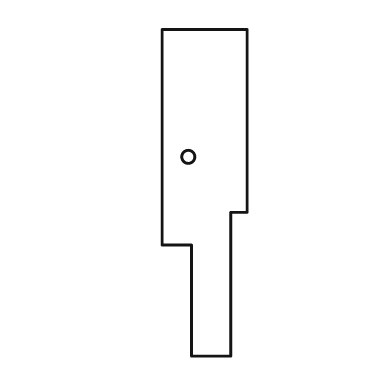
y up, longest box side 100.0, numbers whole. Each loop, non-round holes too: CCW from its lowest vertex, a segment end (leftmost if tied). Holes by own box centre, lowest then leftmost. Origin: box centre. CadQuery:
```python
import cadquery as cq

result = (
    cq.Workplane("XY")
    .moveTo(-4.0, -50.0)
    .lineTo(8.0, -50.0)
    .lineTo(8.0, -6.0)
    .lineTo(13.0, -6.0)
    .lineTo(13.0, 50.0)
    .lineTo(-13.0, 50.0)
    .lineTo(-13.0, -16.0)
    .lineTo(-4.0, -16.0)
    .close()
    .moveTo(-5.0, 11.0)
    .circle(2.0)
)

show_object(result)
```